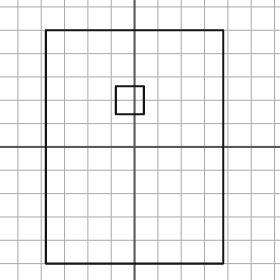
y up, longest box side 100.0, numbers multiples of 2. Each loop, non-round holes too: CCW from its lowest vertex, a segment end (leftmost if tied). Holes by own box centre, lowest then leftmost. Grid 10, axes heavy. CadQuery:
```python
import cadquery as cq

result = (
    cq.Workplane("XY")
    .moveTo(-38.0, -50.0)
    .lineTo(38.0, -50.0)
    .lineTo(38.0, 50.0)
    .lineTo(-38.0, 50.0)
    .close()
    .moveTo(-8.0, 14.0)
    .lineTo(4.0, 14.0)
    .lineTo(4.0, 26.0)
    .lineTo(-8.0, 26.0)
    .close()
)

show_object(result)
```